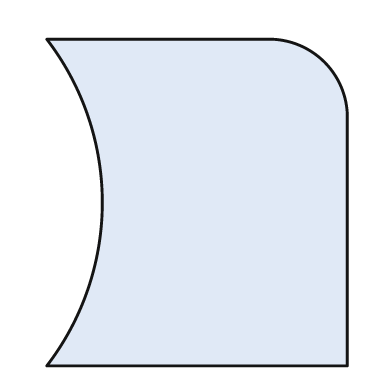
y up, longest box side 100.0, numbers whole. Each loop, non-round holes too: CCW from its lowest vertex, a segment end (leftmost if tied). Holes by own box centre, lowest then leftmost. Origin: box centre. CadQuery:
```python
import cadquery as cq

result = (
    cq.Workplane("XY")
    .moveTo(-46.0, -50.0)
    .lineTo(46.0, -50.0)
    .lineTo(46.0, 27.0)
    .threePointArc((39.0, 43.0), (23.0, 50.0))
    .lineTo(-46.0, 50.0)
    .threePointArc((-29.0, 0.0), (-46.0, -50.0))
    .close()
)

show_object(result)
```